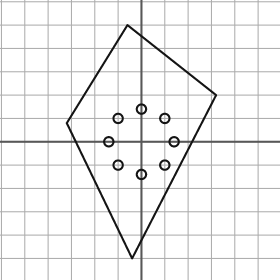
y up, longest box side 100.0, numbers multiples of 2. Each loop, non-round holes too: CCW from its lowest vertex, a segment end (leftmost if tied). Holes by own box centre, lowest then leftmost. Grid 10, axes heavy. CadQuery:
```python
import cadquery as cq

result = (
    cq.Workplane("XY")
    .moveTo(-4.0, -50.0)
    .lineTo(32.0, 20.0)
    .lineTo(-6.0, 50.0)
    .lineTo(-32.0, 8.0)
    .close()
    .moveTo(0.0, -14.0)
    .circle(2.0)
    .moveTo(-10.0, -10.0)
    .circle(2.0)
    .moveTo(10.0, -10.0)
    .circle(2.0)
    .moveTo(-14.0, 0.0)
    .circle(2.0)
    .moveTo(14.0, 0.0)
    .circle(2.0)
    .moveTo(-10.0, 10.0)
    .circle(2.0)
    .moveTo(10.0, 10.0)
    .circle(2.0)
    .moveTo(0.0, 14.0)
    .circle(2.0)
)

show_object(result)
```